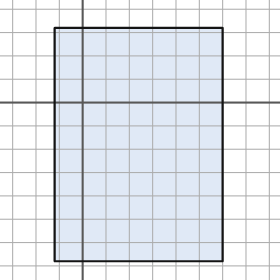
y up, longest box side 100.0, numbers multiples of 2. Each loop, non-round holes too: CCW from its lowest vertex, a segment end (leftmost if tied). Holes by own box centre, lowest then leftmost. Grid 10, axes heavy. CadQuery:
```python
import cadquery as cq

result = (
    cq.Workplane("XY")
    .moveTo(-12.0, -68.0)
    .lineTo(60.0, -68.0)
    .lineTo(60.0, 32.0)
    .lineTo(-12.0, 32.0)
    .close()
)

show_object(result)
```